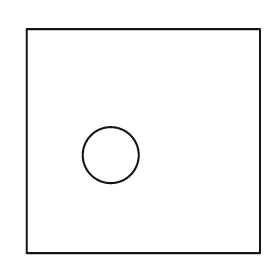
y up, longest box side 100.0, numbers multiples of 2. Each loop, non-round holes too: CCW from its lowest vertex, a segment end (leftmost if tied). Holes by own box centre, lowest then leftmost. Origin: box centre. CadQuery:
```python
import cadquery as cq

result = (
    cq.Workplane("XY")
    .moveTo(-50.0, -48.0)
    .lineTo(50.0, -48.0)
    .lineTo(50.0, 48.0)
    .lineTo(-50.0, 48.0)
    .close()
    .moveTo(-14.0, -6.0)
    .circle(12.0)
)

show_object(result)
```